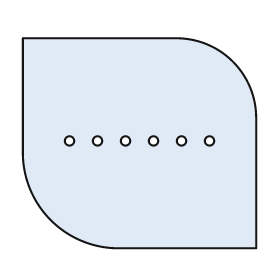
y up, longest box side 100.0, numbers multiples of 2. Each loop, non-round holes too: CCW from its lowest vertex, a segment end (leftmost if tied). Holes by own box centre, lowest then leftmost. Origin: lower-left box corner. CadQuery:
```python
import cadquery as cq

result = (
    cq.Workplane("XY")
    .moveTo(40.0, 0.0)
    .lineTo(100.0, 0.0)
    .lineTo(100.0, 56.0)
    .threePointArc((90.0, 80.0), (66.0, 90.0))
    .lineTo(0.0, 90.0)
    .lineTo(0.0, 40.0)
    .threePointArc((12.0, 12.0), (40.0, 0.0))
    .close()
    .moveTo(20.0, 46.0)
    .circle(2.0)
    .moveTo(32.0, 46.0)
    .circle(2.0)
    .moveTo(44.0, 46.0)
    .circle(2.0)
    .moveTo(56.0, 46.0)
    .circle(2.0)
    .moveTo(68.0, 46.0)
    .circle(2.0)
    .moveTo(80.0, 46.0)
    .circle(2.0)
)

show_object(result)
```